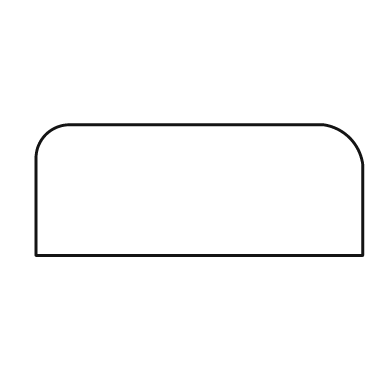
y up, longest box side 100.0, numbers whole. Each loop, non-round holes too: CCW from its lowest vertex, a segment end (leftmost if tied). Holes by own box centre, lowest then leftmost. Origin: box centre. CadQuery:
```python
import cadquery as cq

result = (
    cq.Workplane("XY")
    .moveTo(-50.0, -20.0)
    .lineTo(50.0, -20.0)
    .lineTo(50.0, 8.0)
    .threePointArc((46.0, 16.0), (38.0, 20.0))
    .lineTo(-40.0, 20.0)
    .threePointArc((-47.0, 17.0), (-50.0, 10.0))
    .close()
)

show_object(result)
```